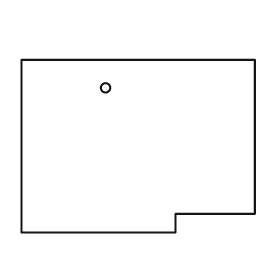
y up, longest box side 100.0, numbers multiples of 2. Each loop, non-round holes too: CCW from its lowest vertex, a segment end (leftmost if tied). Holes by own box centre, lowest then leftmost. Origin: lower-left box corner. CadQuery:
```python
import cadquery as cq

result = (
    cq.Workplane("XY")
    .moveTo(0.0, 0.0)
    .lineTo(66.0, 0.0)
    .lineTo(66.0, 8.0)
    .lineTo(100.0, 8.0)
    .lineTo(100.0, 74.0)
    .lineTo(0.0, 74.0)
    .close()
    .moveTo(36.0, 62.0)
    .circle(2.0)
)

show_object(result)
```